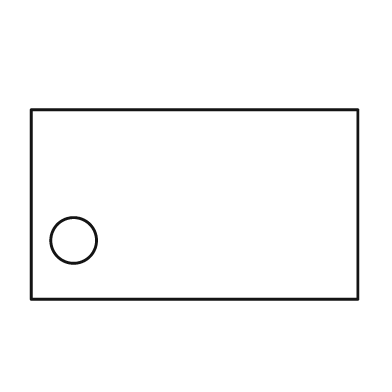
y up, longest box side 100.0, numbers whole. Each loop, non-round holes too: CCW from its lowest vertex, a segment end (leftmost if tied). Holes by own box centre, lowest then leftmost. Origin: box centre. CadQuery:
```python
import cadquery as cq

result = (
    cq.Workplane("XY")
    .moveTo(-50.0, -29.0)
    .lineTo(50.0, -29.0)
    .lineTo(50.0, 29.0)
    .lineTo(-50.0, 29.0)
    .close()
    .moveTo(-37.0, -11.0)
    .circle(7.0)
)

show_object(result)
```